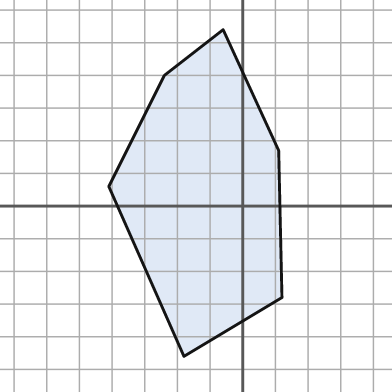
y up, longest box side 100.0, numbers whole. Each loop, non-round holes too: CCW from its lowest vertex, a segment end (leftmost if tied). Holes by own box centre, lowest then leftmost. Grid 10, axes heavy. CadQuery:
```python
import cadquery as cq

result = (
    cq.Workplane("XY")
    .moveTo(-18.0, -46.0)
    .lineTo(12.0, -28.0)
    .lineTo(11.0, 17.0)
    .lineTo(-6.0, 54.0)
    .lineTo(-24.0, 40.0)
    .lineTo(-41.0, 6.0)
    .close()
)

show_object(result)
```